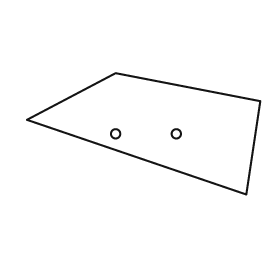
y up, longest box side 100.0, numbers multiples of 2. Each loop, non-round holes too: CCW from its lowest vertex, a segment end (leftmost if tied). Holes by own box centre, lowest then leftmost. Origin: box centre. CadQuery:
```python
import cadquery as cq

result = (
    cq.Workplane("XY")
    .moveTo(44.0, -26.0)
    .lineTo(50.0, 14.0)
    .lineTo(-12.0, 26.0)
    .lineTo(-50.0, 6.0)
    .close()
    .moveTo(-12.0, 0.0)
    .circle(2.0)
    .moveTo(14.0, 0.0)
    .circle(2.0)
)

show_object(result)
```